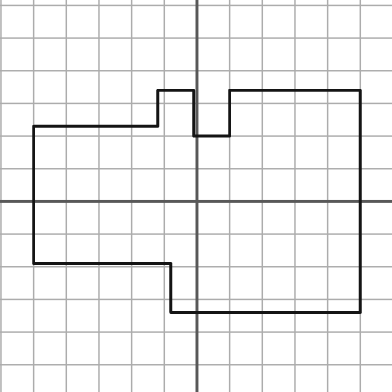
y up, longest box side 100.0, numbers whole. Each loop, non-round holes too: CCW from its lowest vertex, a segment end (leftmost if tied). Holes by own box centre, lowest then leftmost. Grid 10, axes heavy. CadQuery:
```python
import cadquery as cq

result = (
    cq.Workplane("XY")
    .moveTo(-8.0, -34.0)
    .lineTo(50.0, -34.0)
    .lineTo(50.0, 34.0)
    .lineTo(10.0, 34.0)
    .lineTo(10.0, 20.0)
    .lineTo(-1.0, 20.0)
    .lineTo(-1.0, 34.0)
    .lineTo(-12.0, 34.0)
    .lineTo(-12.0, 23.0)
    .lineTo(-50.0, 23.0)
    .lineTo(-50.0, -19.0)
    .lineTo(-8.0, -19.0)
    .close()
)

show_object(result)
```